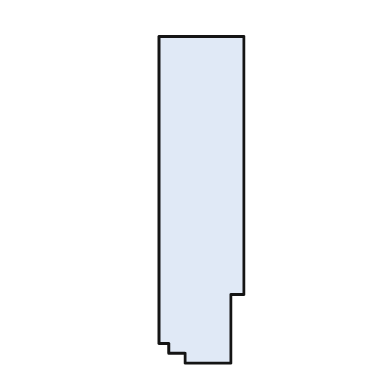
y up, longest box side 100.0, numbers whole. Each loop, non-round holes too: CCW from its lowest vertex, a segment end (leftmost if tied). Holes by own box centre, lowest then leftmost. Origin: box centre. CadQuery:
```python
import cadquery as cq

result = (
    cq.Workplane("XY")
    .moveTo(-5.0, -50.0)
    .lineTo(9.0, -50.0)
    .lineTo(9.0, -29.0)
    .lineTo(13.0, -29.0)
    .lineTo(13.0, 50.0)
    .lineTo(-13.0, 50.0)
    .lineTo(-13.0, -44.0)
    .lineTo(-10.0, -44.0)
    .lineTo(-10.0, -47.0)
    .lineTo(-5.0, -47.0)
    .close()
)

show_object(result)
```